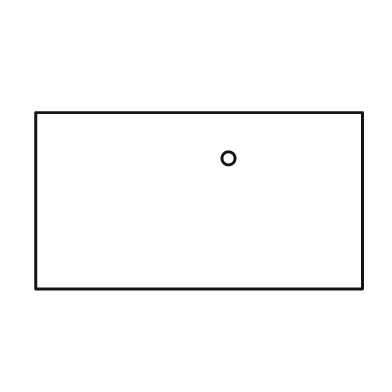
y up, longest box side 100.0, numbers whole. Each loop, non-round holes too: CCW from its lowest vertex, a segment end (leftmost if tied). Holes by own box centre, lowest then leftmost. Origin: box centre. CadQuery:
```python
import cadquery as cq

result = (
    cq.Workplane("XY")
    .moveTo(-50.0, -27.0)
    .lineTo(50.0, -27.0)
    .lineTo(50.0, 27.0)
    .lineTo(-50.0, 27.0)
    .close()
    .moveTo(9.0, 13.0)
    .circle(2.0)
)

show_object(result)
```